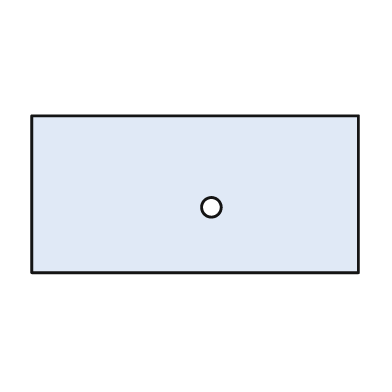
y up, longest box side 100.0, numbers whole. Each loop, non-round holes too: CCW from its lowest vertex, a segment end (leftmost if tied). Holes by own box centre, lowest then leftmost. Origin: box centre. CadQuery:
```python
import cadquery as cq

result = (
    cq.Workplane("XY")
    .moveTo(-50.0, -24.0)
    .lineTo(50.0, -24.0)
    .lineTo(50.0, 24.0)
    .lineTo(-50.0, 24.0)
    .close()
    .moveTo(5.0, -4.0)
    .circle(3.0)
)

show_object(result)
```